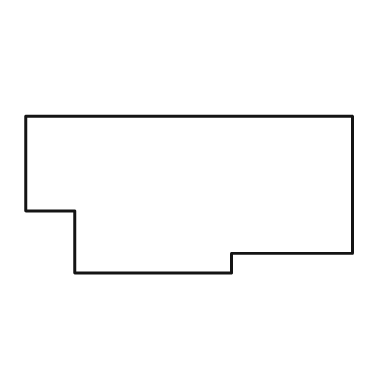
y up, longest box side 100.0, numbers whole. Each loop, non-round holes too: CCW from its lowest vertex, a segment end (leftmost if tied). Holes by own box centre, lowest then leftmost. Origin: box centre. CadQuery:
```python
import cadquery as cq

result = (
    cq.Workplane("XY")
    .moveTo(-35.0, -24.0)
    .lineTo(13.0, -24.0)
    .lineTo(13.0, -18.0)
    .lineTo(50.0, -18.0)
    .lineTo(50.0, 24.0)
    .lineTo(-50.0, 24.0)
    .lineTo(-50.0, -5.0)
    .lineTo(-35.0, -5.0)
    .close()
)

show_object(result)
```